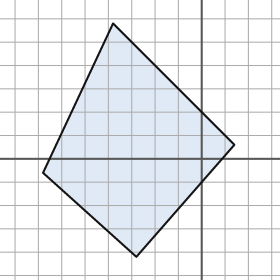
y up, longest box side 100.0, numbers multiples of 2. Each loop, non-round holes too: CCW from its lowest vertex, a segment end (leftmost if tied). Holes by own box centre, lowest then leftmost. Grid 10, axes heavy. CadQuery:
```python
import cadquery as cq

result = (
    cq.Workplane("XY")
    .moveTo(-28.0, -42.0)
    .lineTo(14.0, 6.0)
    .lineTo(-38.0, 58.0)
    .lineTo(-68.0, -6.0)
    .close()
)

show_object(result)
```